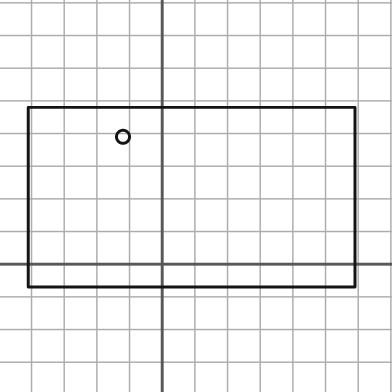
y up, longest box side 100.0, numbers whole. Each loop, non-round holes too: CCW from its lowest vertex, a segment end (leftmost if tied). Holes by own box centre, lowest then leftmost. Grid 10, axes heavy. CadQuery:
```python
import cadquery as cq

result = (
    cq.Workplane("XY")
    .moveTo(-41.0, -7.0)
    .lineTo(59.0, -7.0)
    .lineTo(59.0, 48.0)
    .lineTo(-41.0, 48.0)
    .close()
    .moveTo(-12.0, 39.0)
    .circle(2.0)
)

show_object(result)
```